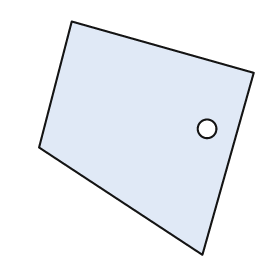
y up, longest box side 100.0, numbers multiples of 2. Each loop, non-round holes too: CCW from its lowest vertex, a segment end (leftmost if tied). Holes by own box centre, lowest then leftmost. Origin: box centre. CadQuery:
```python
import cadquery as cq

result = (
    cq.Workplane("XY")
    .moveTo(24.0, -50.0)
    .lineTo(46.0, 28.0)
    .lineTo(-32.0, 50.0)
    .lineTo(-46.0, -4.0)
    .close()
    .moveTo(26.0, 4.0)
    .circle(4.0)
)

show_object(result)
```